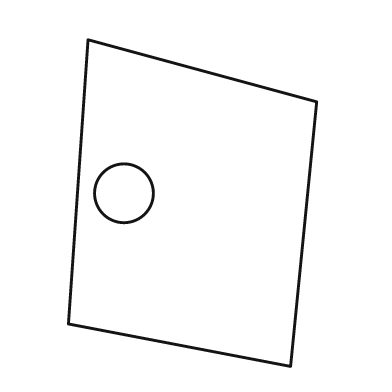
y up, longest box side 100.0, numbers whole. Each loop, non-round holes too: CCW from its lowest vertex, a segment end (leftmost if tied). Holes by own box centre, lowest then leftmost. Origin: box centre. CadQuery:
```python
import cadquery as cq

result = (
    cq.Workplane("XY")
    .moveTo(30.0, -50.0)
    .lineTo(38.0, 31.0)
    .lineTo(-32.0, 50.0)
    .lineTo(-38.0, -37.0)
    .close()
    .moveTo(-21.0, 3.0)
    .circle(9.0)
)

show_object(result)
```